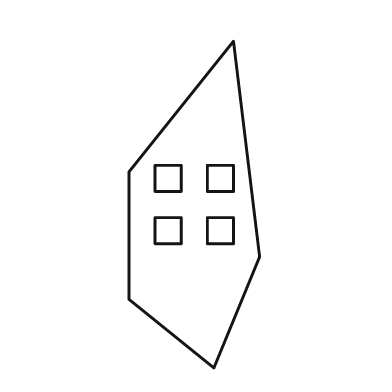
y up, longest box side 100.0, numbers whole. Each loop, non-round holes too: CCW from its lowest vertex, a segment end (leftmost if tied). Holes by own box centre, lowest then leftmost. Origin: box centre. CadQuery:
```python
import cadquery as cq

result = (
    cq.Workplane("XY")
    .moveTo(6.0, -50.0)
    .lineTo(20.0, -16.0)
    .lineTo(12.0, 50.0)
    .lineTo(-20.0, 10.0)
    .lineTo(-20.0, -29.0)
    .close()
    .moveTo(-12.0, -12.0)
    .lineTo(-4.0, -12.0)
    .lineTo(-4.0, -4.0)
    .lineTo(-12.0, -4.0)
    .close()
    .moveTo(4.0, -12.0)
    .lineTo(12.0, -12.0)
    .lineTo(12.0, -4.0)
    .lineTo(4.0, -4.0)
    .close()
    .moveTo(-12.0, 4.0)
    .lineTo(-4.0, 4.0)
    .lineTo(-4.0, 12.0)
    .lineTo(-12.0, 12.0)
    .close()
    .moveTo(4.0, 4.0)
    .lineTo(12.0, 4.0)
    .lineTo(12.0, 12.0)
    .lineTo(4.0, 12.0)
    .close()
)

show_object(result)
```